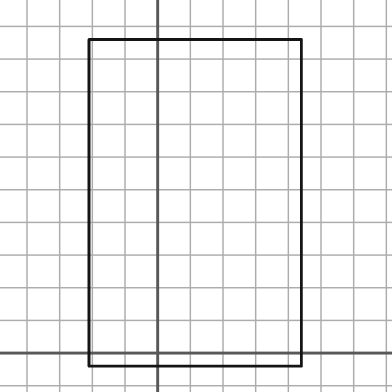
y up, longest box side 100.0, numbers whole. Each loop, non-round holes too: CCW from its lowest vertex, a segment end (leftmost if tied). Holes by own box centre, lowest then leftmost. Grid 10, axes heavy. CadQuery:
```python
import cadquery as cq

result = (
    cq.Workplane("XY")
    .moveTo(-21.0, -4.0)
    .lineTo(44.0, -4.0)
    .lineTo(44.0, 96.0)
    .lineTo(-21.0, 96.0)
    .close()
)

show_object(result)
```